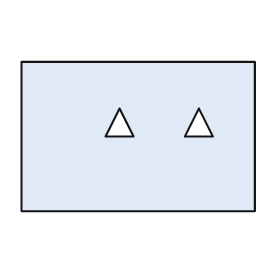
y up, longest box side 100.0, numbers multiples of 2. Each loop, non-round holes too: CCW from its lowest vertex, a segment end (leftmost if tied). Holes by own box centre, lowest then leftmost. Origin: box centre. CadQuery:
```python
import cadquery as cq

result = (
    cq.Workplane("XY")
    .moveTo(-50.0, -32.0)
    .lineTo(50.0, -32.0)
    .lineTo(50.0, 32.0)
    .lineTo(-50.0, 32.0)
    .close()
    .moveTo(-14.0, 0.0)
    .lineTo(-2.0, 0.0)
    .lineTo(-8.0, 12.0)
    .close()
    .moveTo(20.0, 0.0)
    .lineTo(32.0, 0.0)
    .lineTo(26.0, 12.0)
    .close()
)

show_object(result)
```